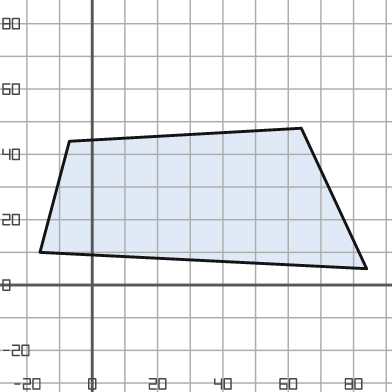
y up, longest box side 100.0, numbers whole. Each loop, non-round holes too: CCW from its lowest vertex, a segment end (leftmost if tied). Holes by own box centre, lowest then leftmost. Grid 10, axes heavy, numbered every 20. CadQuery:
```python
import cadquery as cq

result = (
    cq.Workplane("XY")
    .moveTo(84.0, 5.0)
    .lineTo(64.0, 48.0)
    .lineTo(-7.0, 44.0)
    .lineTo(-16.0, 10.0)
    .close()
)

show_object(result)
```